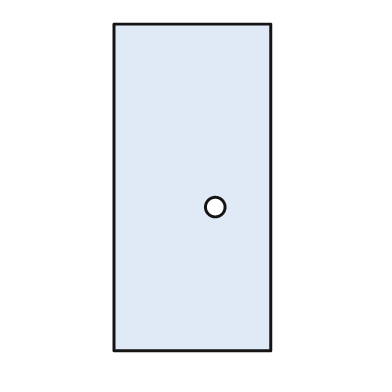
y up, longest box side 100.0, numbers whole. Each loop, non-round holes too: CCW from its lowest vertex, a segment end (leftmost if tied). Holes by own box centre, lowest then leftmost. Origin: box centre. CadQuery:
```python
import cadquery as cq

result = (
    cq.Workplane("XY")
    .moveTo(-24.0, -50.0)
    .lineTo(24.0, -50.0)
    .lineTo(24.0, 50.0)
    .lineTo(-24.0, 50.0)
    .close()
    .moveTo(7.0, -6.0)
    .circle(3.0)
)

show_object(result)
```